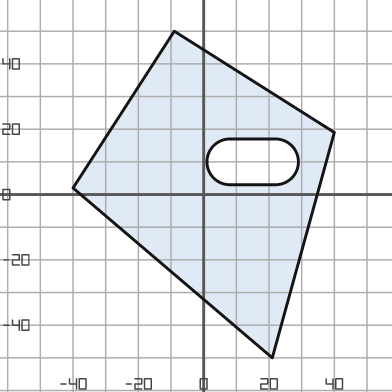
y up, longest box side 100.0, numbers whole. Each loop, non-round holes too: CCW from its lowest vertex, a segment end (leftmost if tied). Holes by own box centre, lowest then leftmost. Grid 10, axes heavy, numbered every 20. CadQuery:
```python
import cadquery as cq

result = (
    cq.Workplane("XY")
    .moveTo(21.0, -50.0)
    .lineTo(40.0, 19.0)
    .lineTo(-9.0, 50.0)
    .lineTo(-40.0, 2.0)
    .close()
    .moveTo(8.0, 3.0)
    .lineTo(22.0, 3.0)
    .threePointArc((29.0, 10.0), (22.0, 17.0))
    .lineTo(8.0, 17.0)
    .threePointArc((1.0, 10.0), (8.0, 3.0))
    .close()
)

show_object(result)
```